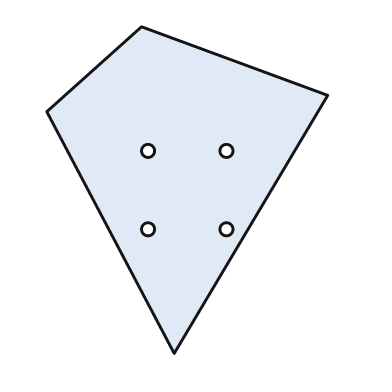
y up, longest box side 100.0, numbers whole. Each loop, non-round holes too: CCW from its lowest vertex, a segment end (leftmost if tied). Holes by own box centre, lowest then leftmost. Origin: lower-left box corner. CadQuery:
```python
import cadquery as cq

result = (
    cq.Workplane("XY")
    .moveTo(39.0, 0.0)
    .lineTo(86.0, 79.0)
    .lineTo(29.0, 100.0)
    .lineTo(0.0, 74.0)
    .close()
    .moveTo(31.0, 38.0)
    .circle(2.0)
    .moveTo(55.0, 38.0)
    .circle(2.0)
    .moveTo(31.0, 62.0)
    .circle(2.0)
    .moveTo(55.0, 62.0)
    .circle(2.0)
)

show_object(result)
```